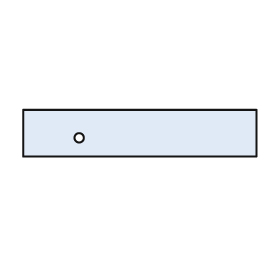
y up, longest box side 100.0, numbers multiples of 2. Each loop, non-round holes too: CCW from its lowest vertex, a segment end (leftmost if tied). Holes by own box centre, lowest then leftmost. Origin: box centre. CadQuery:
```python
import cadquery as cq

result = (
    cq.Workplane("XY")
    .moveTo(-50.0, -10.0)
    .lineTo(50.0, -10.0)
    .lineTo(50.0, 10.0)
    .lineTo(-50.0, 10.0)
    .close()
    .moveTo(-26.0, -2.0)
    .circle(2.0)
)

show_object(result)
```